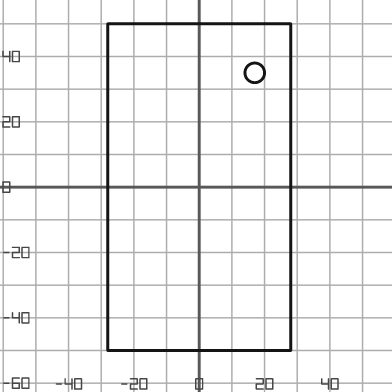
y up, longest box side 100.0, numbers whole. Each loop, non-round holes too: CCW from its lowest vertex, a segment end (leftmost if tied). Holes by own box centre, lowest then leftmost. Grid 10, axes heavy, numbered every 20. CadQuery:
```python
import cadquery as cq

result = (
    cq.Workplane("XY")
    .moveTo(-28.0, -50.0)
    .lineTo(28.0, -50.0)
    .lineTo(28.0, 50.0)
    .lineTo(-28.0, 50.0)
    .close()
    .moveTo(17.0, 35.0)
    .circle(3.0)
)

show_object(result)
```